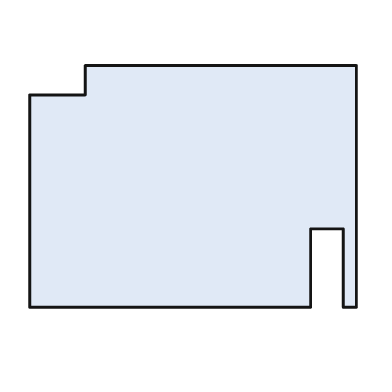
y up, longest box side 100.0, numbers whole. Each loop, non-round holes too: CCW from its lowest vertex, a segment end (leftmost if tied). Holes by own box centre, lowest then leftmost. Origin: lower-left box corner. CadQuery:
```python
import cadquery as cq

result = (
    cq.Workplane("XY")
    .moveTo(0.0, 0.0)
    .lineTo(86.0, 0.0)
    .lineTo(86.0, 24.0)
    .lineTo(96.0, 24.0)
    .lineTo(96.0, 0.0)
    .lineTo(100.0, 0.0)
    .lineTo(100.0, 74.0)
    .lineTo(17.0, 74.0)
    .lineTo(17.0, 65.0)
    .lineTo(0.0, 65.0)
    .close()
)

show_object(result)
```